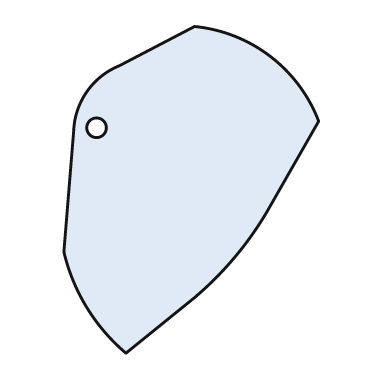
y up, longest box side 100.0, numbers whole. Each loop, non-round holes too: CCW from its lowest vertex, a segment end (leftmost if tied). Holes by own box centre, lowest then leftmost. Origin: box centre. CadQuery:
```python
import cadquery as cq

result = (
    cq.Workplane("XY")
    .moveTo(-20.0, -50.0)
    .lineTo(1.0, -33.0)
    .threePointArc((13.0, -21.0), (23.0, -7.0))
    .lineTo(39.0, 21.0)
    .threePointArc((24.0, 41.0), (1.0, 50.0))
    .lineTo(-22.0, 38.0)
    .threePointArc((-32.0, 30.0), (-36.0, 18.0))
    .lineTo(-39.0, -19.0)
    .threePointArc((-32.0, -36.0), (-20.0, -50.0))
    .close()
    .moveTo(-29.0, 19.0)
    .circle(3.0)
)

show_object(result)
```